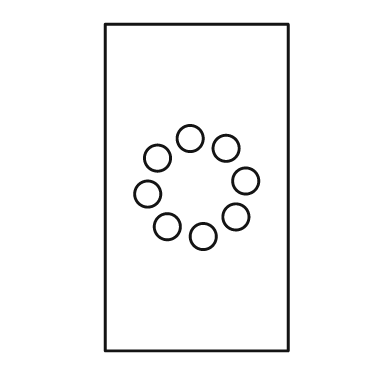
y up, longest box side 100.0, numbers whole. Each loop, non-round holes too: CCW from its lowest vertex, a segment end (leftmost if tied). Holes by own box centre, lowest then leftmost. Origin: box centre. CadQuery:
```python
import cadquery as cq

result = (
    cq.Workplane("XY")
    .moveTo(-28.0, -50.0)
    .lineTo(28.0, -50.0)
    .lineTo(28.0, 50.0)
    .lineTo(-28.0, 50.0)
    .close()
    .moveTo(2.0, -15.0)
    .circle(4.0)
    .moveTo(-9.0, -12.0)
    .circle(4.0)
    .moveTo(12.0, -9.0)
    .circle(4.0)
    .moveTo(-15.0, -2.0)
    .circle(4.0)
    .moveTo(15.0, 2.0)
    .circle(4.0)
    .moveTo(-12.0, 9.0)
    .circle(4.0)
    .moveTo(9.0, 12.0)
    .circle(4.0)
    .moveTo(-2.0, 15.0)
    .circle(4.0)
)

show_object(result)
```